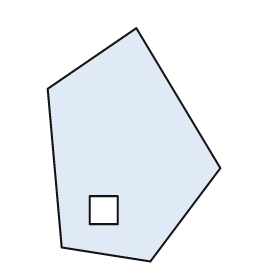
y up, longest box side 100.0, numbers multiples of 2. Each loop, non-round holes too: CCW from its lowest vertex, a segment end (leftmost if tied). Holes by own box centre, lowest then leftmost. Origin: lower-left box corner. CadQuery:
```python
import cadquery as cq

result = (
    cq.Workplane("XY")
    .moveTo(44.0, 0.0)
    .lineTo(74.0, 40.0)
    .lineTo(38.0, 100.0)
    .lineTo(0.0, 74.0)
    .lineTo(6.0, 6.0)
    .close()
    .moveTo(18.0, 16.0)
    .lineTo(30.0, 16.0)
    .lineTo(30.0, 28.0)
    .lineTo(18.0, 28.0)
    .close()
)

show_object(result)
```